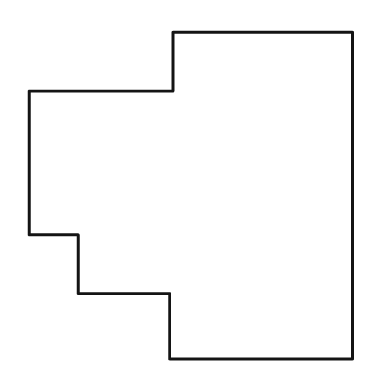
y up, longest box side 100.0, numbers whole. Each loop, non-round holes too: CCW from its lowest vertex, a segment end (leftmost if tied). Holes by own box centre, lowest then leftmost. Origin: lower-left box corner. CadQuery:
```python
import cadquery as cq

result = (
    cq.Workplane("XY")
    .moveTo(43.0, 0.0)
    .lineTo(99.0, 0.0)
    .lineTo(99.0, 100.0)
    .lineTo(44.0, 100.0)
    .lineTo(44.0, 82.0)
    .lineTo(0.0, 82.0)
    .lineTo(0.0, 38.0)
    .lineTo(15.0, 38.0)
    .lineTo(15.0, 20.0)
    .lineTo(43.0, 20.0)
    .close()
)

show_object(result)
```